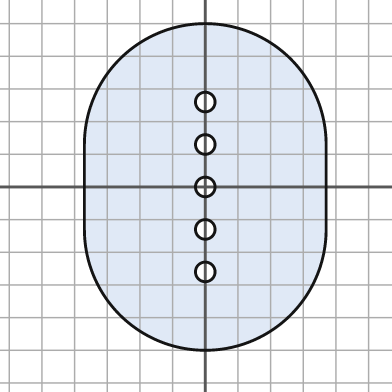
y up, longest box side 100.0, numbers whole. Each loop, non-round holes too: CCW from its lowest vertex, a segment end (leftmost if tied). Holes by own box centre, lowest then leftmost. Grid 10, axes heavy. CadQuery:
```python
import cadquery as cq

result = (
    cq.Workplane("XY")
    .moveTo(-37.0, -13.0)
    .threePointArc((0.0, -50.0), (37.0, -13.0))
    .lineTo(37.0, 13.0)
    .threePointArc((0.0, 50.0), (-37.0, 13.0))
    .close()
    .moveTo(0.0, -26.0)
    .circle(3.0)
    .moveTo(0.0, -13.0)
    .circle(3.0)
    .moveTo(0.0, 0.0)
    .circle(3.0)
    .moveTo(0.0, 13.0)
    .circle(3.0)
    .moveTo(0.0, 26.0)
    .circle(3.0)
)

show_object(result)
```